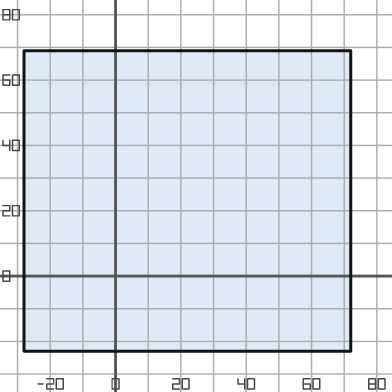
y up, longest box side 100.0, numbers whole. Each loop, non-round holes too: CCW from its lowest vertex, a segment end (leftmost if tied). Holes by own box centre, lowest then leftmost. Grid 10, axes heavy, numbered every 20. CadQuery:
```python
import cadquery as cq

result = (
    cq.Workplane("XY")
    .moveTo(-28.0, -23.0)
    .lineTo(72.0, -23.0)
    .lineTo(72.0, 69.0)
    .lineTo(-28.0, 69.0)
    .close()
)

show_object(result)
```